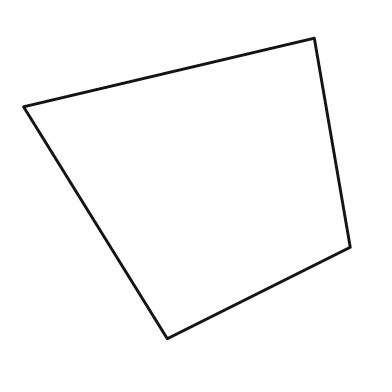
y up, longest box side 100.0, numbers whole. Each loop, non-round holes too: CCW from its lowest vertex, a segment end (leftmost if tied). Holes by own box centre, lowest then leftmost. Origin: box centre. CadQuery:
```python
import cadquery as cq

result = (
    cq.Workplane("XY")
    .moveTo(-6.0, -46.0)
    .lineTo(50.0, -18.0)
    .lineTo(39.0, 46.0)
    .lineTo(-50.0, 25.0)
    .close()
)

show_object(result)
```